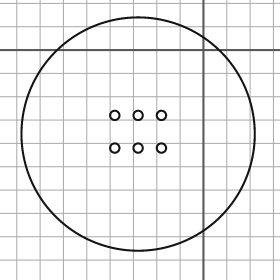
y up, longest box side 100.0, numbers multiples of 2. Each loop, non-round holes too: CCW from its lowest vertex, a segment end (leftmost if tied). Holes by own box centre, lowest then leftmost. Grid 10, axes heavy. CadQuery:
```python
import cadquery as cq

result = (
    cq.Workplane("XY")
    .moveTo(-28.0, -36.0)
    .circle(50.0)
    .moveTo(-38.0, -42.0)
    .circle(2.0)
    .moveTo(-28.0, -42.0)
    .circle(2.0)
    .moveTo(-18.0, -42.0)
    .circle(2.0)
    .moveTo(-38.0, -28.0)
    .circle(2.0)
    .moveTo(-28.0, -28.0)
    .circle(2.0)
    .moveTo(-18.0, -28.0)
    .circle(2.0)
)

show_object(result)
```